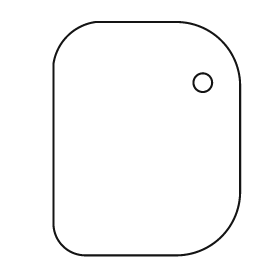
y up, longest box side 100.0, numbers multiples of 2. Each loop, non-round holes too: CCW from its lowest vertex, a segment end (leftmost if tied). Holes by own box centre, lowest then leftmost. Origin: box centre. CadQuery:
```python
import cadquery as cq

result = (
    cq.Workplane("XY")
    .moveTo(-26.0, -50.0)
    .lineTo(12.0, -50.0)
    .threePointArc((32.0, -42.0), (40.0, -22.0))
    .lineTo(40.0, 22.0)
    .threePointArc((32.0, 42.0), (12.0, 50.0))
    .lineTo(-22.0, 50.0)
    .threePointArc((-34.0, 44.0), (-40.0, 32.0))
    .lineTo(-40.0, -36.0)
    .threePointArc((-36.0, -46.0), (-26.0, -50.0))
    .close()
    .moveTo(24.0, 24.0)
    .circle(4.0)
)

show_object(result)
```